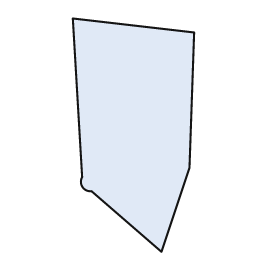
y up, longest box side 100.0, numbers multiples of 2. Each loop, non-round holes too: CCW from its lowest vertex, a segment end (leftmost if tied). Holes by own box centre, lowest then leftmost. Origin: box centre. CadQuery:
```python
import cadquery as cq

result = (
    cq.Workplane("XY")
    .moveTo(12.0, -50.0)
    .lineTo(24.0, -14.0)
    .lineTo(26.0, 44.0)
    .lineTo(-26.0, 50.0)
    .lineTo(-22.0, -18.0)
    .threePointArc((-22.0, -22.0), (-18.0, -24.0))
    .close()
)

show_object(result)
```